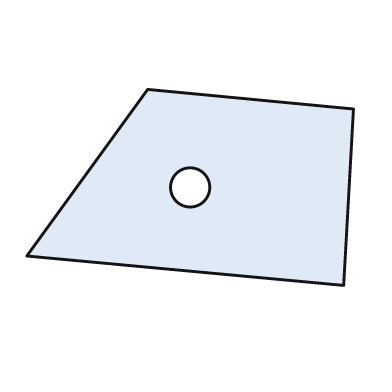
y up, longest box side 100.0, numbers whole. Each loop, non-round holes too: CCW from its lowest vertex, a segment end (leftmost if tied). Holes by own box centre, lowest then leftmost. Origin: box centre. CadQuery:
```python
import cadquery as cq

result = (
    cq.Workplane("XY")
    .moveTo(47.0, -30.0)
    .lineTo(50.0, 24.0)
    .lineTo(-13.0, 30.0)
    .lineTo(-50.0, -21.0)
    .close()
    .moveTo(0.0, 0.0)
    .circle(6.0)
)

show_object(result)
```